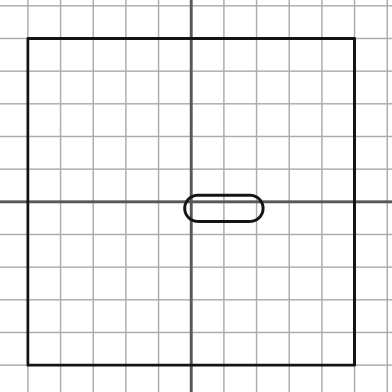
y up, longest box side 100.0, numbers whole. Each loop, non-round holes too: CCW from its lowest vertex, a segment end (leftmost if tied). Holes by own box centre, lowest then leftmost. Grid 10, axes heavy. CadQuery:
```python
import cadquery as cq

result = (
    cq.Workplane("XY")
    .moveTo(-50.0, -50.0)
    .lineTo(50.0, -50.0)
    .lineTo(50.0, 50.0)
    .lineTo(-50.0, 50.0)
    .close()
    .moveTo(2.0, -6.0)
    .lineTo(18.0, -6.0)
    .threePointArc((22.0, -2.0), (18.0, 2.0))
    .lineTo(2.0, 2.0)
    .threePointArc((-2.0, -2.0), (2.0, -6.0))
    .close()
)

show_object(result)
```